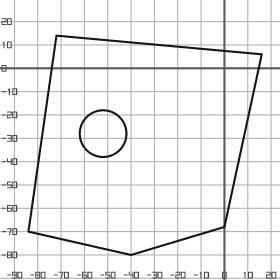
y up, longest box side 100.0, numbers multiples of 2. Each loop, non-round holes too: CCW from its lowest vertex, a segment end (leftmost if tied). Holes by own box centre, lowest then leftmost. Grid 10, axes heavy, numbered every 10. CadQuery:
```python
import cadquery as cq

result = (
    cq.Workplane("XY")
    .moveTo(-40.0, -80.0)
    .lineTo(0.0, -68.0)
    .lineTo(16.0, 6.0)
    .lineTo(-72.0, 14.0)
    .lineTo(-84.0, -70.0)
    .close()
    .moveTo(-52.0, -28.0)
    .circle(10.0)
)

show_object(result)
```